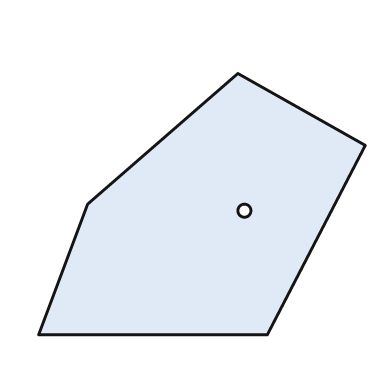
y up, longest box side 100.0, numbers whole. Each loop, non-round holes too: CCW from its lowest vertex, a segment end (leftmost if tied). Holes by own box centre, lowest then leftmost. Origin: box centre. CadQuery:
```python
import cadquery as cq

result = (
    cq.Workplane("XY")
    .moveTo(-50.0, -40.0)
    .lineTo(20.0, -40.0)
    .lineTo(50.0, 18.0)
    .lineTo(11.0, 40.0)
    .lineTo(-35.0, 0.0)
    .close()
    .moveTo(13.0, -2.0)
    .circle(2.0)
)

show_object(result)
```